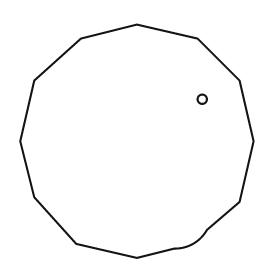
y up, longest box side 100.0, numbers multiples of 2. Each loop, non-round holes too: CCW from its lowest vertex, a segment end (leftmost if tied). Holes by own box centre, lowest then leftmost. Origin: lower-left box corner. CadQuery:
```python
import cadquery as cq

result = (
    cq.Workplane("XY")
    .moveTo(50.0, 0.0)
    .lineTo(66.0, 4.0)
    .threePointArc((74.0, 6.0), (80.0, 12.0))
    .lineTo(94.0, 24.0)
    .lineTo(100.0, 50.0)
    .lineTo(94.0, 76.0)
    .lineTo(76.0, 94.0)
    .lineTo(50.0, 100.0)
    .lineTo(26.0, 94.0)
    .lineTo(6.0, 76.0)
    .lineTo(0.0, 50.0)
    .lineTo(6.0, 26.0)
    .lineTo(24.0, 6.0)
    .close()
    .moveTo(78.0, 68.0)
    .circle(2.0)
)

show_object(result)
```